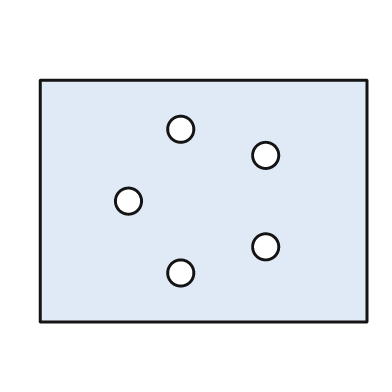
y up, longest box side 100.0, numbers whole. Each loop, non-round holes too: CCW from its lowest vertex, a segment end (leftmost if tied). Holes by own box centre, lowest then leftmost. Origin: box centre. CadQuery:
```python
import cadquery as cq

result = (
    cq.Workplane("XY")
    .moveTo(-50.0, -37.0)
    .lineTo(50.0, -37.0)
    .lineTo(50.0, 37.0)
    .lineTo(-50.0, 37.0)
    .close()
    .moveTo(-7.0, -22.0)
    .circle(4.0)
    .moveTo(19.0, -14.0)
    .circle(4.0)
    .moveTo(-23.0, 0.0)
    .circle(4.0)
    .moveTo(19.0, 14.0)
    .circle(4.0)
    .moveTo(-7.0, 22.0)
    .circle(4.0)
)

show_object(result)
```